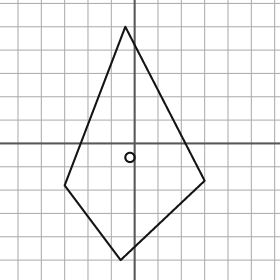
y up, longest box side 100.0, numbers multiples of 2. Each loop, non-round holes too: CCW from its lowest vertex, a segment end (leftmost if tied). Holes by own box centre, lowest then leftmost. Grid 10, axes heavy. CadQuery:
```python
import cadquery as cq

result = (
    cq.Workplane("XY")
    .moveTo(-6.0, -50.0)
    .lineTo(30.0, -16.0)
    .lineTo(-4.0, 50.0)
    .lineTo(-30.0, -18.0)
    .close()
    .moveTo(-2.0, -6.0)
    .circle(2.0)
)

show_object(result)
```